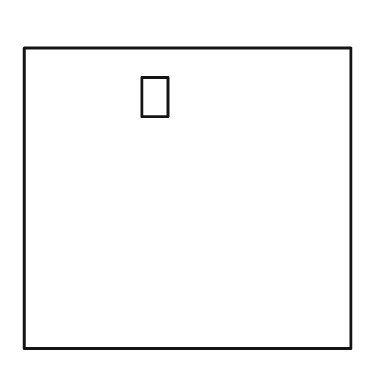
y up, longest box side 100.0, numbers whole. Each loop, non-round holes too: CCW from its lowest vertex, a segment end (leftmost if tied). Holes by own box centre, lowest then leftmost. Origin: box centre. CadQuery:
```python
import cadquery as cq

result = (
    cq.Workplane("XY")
    .moveTo(-50.0, -46.0)
    .lineTo(50.0, -46.0)
    .lineTo(50.0, 46.0)
    .lineTo(-50.0, 46.0)
    .close()
    .moveTo(-14.0, 25.0)
    .lineTo(-6.0, 25.0)
    .lineTo(-6.0, 37.0)
    .lineTo(-14.0, 37.0)
    .close()
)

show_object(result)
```